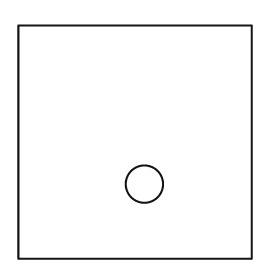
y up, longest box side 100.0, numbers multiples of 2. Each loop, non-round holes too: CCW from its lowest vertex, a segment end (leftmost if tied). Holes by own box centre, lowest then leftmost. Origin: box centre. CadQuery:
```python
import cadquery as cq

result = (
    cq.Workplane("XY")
    .moveTo(-50.0, -50.0)
    .lineTo(50.0, -50.0)
    .lineTo(50.0, 50.0)
    .lineTo(-50.0, 50.0)
    .close()
    .moveTo(4.0, -18.0)
    .circle(8.0)
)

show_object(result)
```